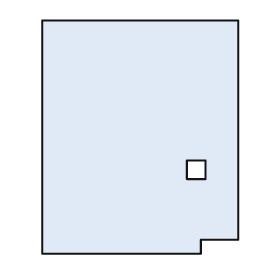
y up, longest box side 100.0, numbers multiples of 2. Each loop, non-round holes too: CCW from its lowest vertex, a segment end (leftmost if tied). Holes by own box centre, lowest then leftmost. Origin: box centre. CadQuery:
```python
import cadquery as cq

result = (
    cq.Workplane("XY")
    .moveTo(-42.0, -50.0)
    .lineTo(26.0, -50.0)
    .lineTo(26.0, -44.0)
    .lineTo(42.0, -44.0)
    .lineTo(42.0, 50.0)
    .lineTo(-42.0, 50.0)
    .close()
    .moveTo(20.0, -18.0)
    .lineTo(28.0, -18.0)
    .lineTo(28.0, -10.0)
    .lineTo(20.0, -10.0)
    .close()
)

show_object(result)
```